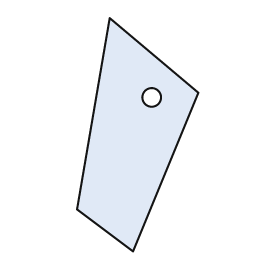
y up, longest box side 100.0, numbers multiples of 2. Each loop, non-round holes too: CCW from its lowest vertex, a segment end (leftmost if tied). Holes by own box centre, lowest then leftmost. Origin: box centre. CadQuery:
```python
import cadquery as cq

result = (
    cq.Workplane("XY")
    .moveTo(-2.0, -50.0)
    .lineTo(26.0, 18.0)
    .lineTo(-12.0, 50.0)
    .lineTo(-26.0, -32.0)
    .close()
    .moveTo(6.0, 16.0)
    .circle(4.0)
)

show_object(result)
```